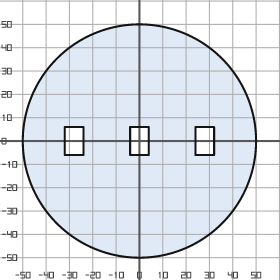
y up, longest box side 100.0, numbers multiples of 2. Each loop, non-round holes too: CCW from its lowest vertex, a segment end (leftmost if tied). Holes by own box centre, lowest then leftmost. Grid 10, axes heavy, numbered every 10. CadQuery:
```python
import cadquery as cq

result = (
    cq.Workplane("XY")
    .moveTo(0.0, 0.0)
    .circle(50.0)
    .moveTo(-32.0, -6.0)
    .lineTo(-24.0, -6.0)
    .lineTo(-24.0, 6.0)
    .lineTo(-32.0, 6.0)
    .close()
    .moveTo(-4.0, -6.0)
    .lineTo(4.0, -6.0)
    .lineTo(4.0, 6.0)
    .lineTo(-4.0, 6.0)
    .close()
    .moveTo(24.0, -6.0)
    .lineTo(32.0, -6.0)
    .lineTo(32.0, 6.0)
    .lineTo(24.0, 6.0)
    .close()
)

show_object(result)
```